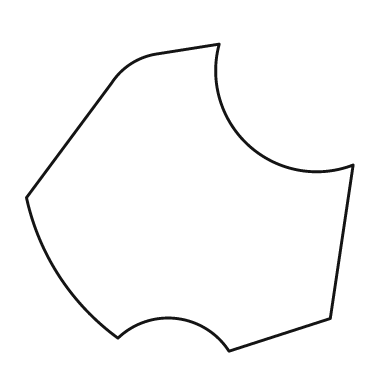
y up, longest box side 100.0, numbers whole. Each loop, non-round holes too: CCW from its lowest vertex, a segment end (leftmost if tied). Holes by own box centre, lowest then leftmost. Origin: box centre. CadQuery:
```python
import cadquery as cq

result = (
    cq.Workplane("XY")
    .moveTo(12.0, -47.0)
    .lineTo(43.0, -37.0)
    .lineTo(50.0, 10.0)
    .threePointArc((18.0, 16.0), (9.0, 47.0))
    .lineTo(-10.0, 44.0)
    .threePointArc((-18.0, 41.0), (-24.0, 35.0))
    .lineTo(-50.0, 0.0)
    .threePointArc((-40.0, -24.0), (-22.0, -43.0))
    .threePointArc((-4.0, -37.0), (12.0, -47.0))
    .close()
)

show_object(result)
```